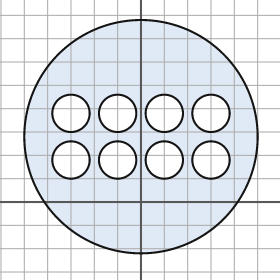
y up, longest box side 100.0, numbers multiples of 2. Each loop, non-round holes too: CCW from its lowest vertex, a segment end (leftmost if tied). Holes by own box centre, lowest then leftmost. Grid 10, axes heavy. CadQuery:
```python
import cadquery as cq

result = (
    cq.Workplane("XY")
    .moveTo(0.0, 28.0)
    .circle(50.0)
    .moveTo(-30.0, 18.0)
    .circle(8.0)
    .moveTo(-10.0, 18.0)
    .circle(8.0)
    .moveTo(10.0, 18.0)
    .circle(8.0)
    .moveTo(30.0, 18.0)
    .circle(8.0)
    .moveTo(-30.0, 38.0)
    .circle(8.0)
    .moveTo(-10.0, 38.0)
    .circle(8.0)
    .moveTo(10.0, 38.0)
    .circle(8.0)
    .moveTo(30.0, 38.0)
    .circle(8.0)
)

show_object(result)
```